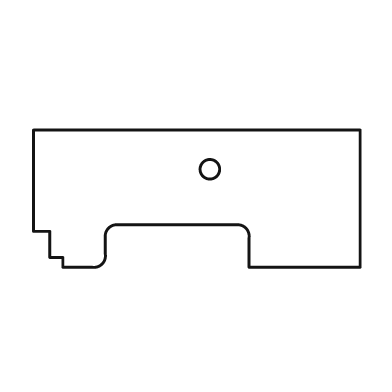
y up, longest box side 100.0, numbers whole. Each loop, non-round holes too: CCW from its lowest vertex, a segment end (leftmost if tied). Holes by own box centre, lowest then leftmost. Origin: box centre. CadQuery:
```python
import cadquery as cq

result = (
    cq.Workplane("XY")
    .moveTo(-41.0, -21.0)
    .lineTo(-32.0, -21.0)
    .threePointArc((-29.0, -20.0), (-28.0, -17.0))
    .lineTo(-28.0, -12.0)
    .threePointArc((-27.0, -9.0), (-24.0, -8.0))
    .lineTo(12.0, -8.0)
    .threePointArc((15.0, -9.0), (16.0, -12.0))
    .lineTo(16.0, -21.0)
    .lineTo(50.0, -21.0)
    .lineTo(50.0, 21.0)
    .lineTo(-50.0, 21.0)
    .lineTo(-50.0, -10.0)
    .lineTo(-45.0, -10.0)
    .lineTo(-45.0, -18.0)
    .lineTo(-41.0, -18.0)
    .close()
    .moveTo(4.0, 9.0)
    .circle(3.0)
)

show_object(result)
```